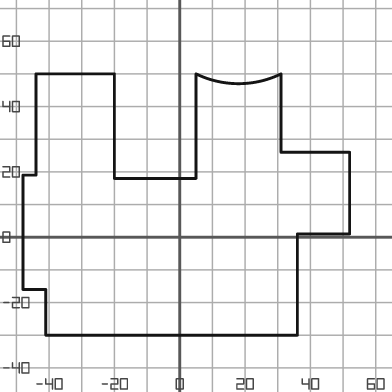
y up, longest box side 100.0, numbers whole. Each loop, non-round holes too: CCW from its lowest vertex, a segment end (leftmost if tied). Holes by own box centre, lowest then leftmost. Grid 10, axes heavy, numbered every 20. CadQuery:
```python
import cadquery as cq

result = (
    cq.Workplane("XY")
    .moveTo(-41.0, -30.0)
    .lineTo(36.0, -30.0)
    .lineTo(36.0, 1.0)
    .lineTo(52.0, 1.0)
    .lineTo(52.0, 26.0)
    .lineTo(31.0, 26.0)
    .lineTo(31.0, 50.0)
    .threePointArc((18.0, 47.0), (5.0, 50.0))
    .lineTo(5.0, 18.0)
    .lineTo(-20.0, 18.0)
    .lineTo(-20.0, 50.0)
    .lineTo(-44.0, 50.0)
    .lineTo(-44.0, 19.0)
    .lineTo(-48.0, 19.0)
    .lineTo(-48.0, -16.0)
    .lineTo(-41.0, -16.0)
    .close()
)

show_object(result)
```